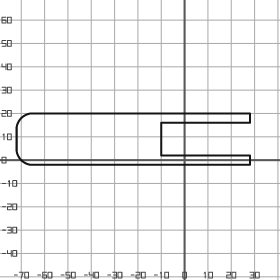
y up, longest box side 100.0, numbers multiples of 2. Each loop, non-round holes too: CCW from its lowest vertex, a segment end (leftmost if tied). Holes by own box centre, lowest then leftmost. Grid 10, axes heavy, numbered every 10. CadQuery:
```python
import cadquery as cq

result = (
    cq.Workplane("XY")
    .moveTo(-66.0, -2.0)
    .lineTo(28.0, -2.0)
    .lineTo(28.0, 2.0)
    .lineTo(-10.0, 2.0)
    .lineTo(-10.0, 16.0)
    .lineTo(28.0, 16.0)
    .lineTo(28.0, 20.0)
    .lineTo(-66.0, 20.0)
    .threePointArc((-70.0, 18.0), (-72.0, 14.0))
    .lineTo(-72.0, 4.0)
    .threePointArc((-70.0, 0.0), (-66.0, -2.0))
    .close()
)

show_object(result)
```